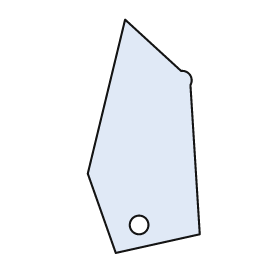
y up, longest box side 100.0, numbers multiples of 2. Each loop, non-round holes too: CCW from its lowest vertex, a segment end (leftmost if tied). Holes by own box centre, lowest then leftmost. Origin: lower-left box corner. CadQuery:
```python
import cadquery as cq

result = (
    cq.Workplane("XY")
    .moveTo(12.0, 0.0)
    .lineTo(48.0, 8.0)
    .lineTo(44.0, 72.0)
    .threePointArc((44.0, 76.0), (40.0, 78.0))
    .lineTo(16.0, 100.0)
    .lineTo(0.0, 34.0)
    .close()
    .moveTo(22.0, 12.0)
    .circle(4.0)
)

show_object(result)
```